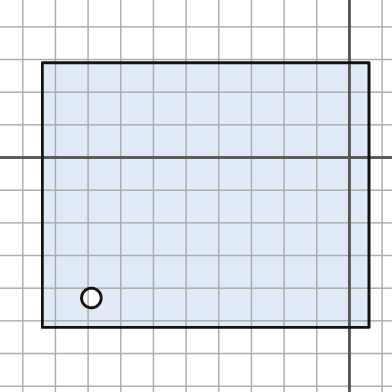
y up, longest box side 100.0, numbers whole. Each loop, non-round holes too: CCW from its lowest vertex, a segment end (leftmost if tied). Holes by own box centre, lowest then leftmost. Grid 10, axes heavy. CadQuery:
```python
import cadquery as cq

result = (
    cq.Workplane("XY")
    .moveTo(-94.0, -52.0)
    .lineTo(6.0, -52.0)
    .lineTo(6.0, 29.0)
    .lineTo(-94.0, 29.0)
    .close()
    .moveTo(-79.0, -43.0)
    .circle(3.0)
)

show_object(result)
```